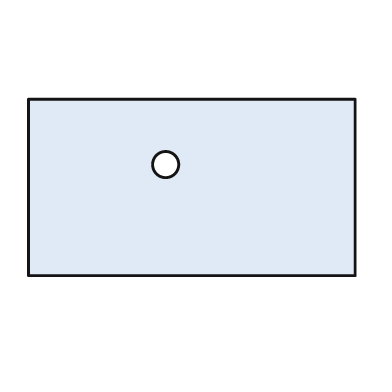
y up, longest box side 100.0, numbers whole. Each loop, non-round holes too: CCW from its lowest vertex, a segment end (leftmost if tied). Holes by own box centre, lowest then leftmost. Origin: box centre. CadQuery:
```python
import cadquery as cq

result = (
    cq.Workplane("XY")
    .moveTo(-50.0, -27.0)
    .lineTo(50.0, -27.0)
    .lineTo(50.0, 27.0)
    .lineTo(-50.0, 27.0)
    .close()
    .moveTo(-8.0, 7.0)
    .circle(4.0)
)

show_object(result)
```